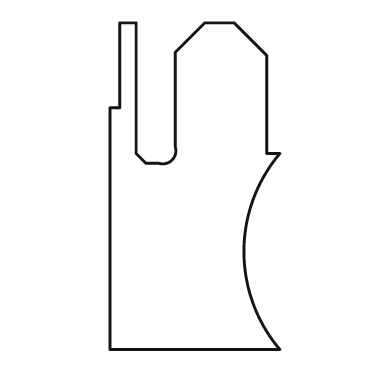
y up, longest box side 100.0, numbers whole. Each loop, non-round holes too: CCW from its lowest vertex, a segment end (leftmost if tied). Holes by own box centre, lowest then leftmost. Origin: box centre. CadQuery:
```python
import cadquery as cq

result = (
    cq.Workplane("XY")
    .moveTo(-26.0, -50.0)
    .lineTo(26.0, -50.0)
    .threePointArc((15.0, -20.0), (26.0, 10.0))
    .lineTo(22.0, 10.0)
    .lineTo(22.0, 40.0)
    .lineTo(12.0, 50.0)
    .lineTo(3.0, 50.0)
    .lineTo(-6.0, 41.0)
    .lineTo(-6.0, 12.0)
    .threePointArc((-7.0, 8.0), (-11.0, 7.0))
    .lineTo(-15.0, 7.0)
    .lineTo(-18.0, 10.0)
    .lineTo(-18.0, 50.0)
    .lineTo(-23.0, 50.0)
    .lineTo(-23.0, 24.0)
    .lineTo(-26.0, 24.0)
    .close()
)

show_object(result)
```